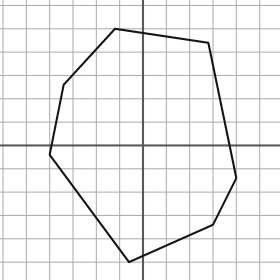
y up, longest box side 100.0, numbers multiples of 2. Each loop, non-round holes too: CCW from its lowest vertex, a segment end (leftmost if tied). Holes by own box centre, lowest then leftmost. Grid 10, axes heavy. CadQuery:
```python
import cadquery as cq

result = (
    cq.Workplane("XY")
    .moveTo(-6.0, -50.0)
    .lineTo(30.0, -34.0)
    .lineTo(40.0, -14.0)
    .lineTo(28.0, 44.0)
    .lineTo(-12.0, 50.0)
    .lineTo(-34.0, 26.0)
    .lineTo(-40.0, -4.0)
    .close()
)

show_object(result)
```